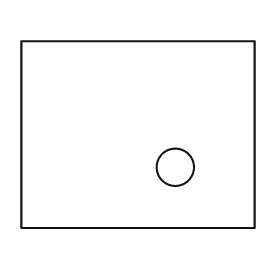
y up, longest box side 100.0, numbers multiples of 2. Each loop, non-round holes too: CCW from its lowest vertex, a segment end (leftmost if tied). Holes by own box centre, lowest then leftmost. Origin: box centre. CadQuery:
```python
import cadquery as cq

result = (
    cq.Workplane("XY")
    .moveTo(-50.0, -40.0)
    .lineTo(50.0, -40.0)
    .lineTo(50.0, 40.0)
    .lineTo(-50.0, 40.0)
    .close()
    .moveTo(16.0, -14.0)
    .circle(8.0)
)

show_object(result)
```